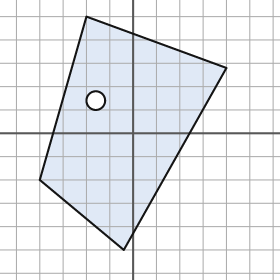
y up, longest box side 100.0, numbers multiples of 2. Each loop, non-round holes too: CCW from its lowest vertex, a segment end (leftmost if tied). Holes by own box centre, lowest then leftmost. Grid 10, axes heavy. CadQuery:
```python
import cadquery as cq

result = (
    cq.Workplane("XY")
    .moveTo(-4.0, -50.0)
    .lineTo(40.0, 28.0)
    .lineTo(-20.0, 50.0)
    .lineTo(-40.0, -20.0)
    .close()
    .moveTo(-16.0, 14.0)
    .circle(4.0)
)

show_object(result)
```